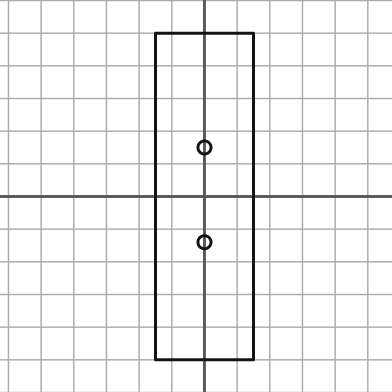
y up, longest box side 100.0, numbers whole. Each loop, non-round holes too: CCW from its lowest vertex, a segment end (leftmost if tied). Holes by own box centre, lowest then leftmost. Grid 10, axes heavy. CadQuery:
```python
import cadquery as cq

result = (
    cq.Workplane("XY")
    .moveTo(-15.0, -50.0)
    .lineTo(15.0, -50.0)
    .lineTo(15.0, 50.0)
    .lineTo(-15.0, 50.0)
    .close()
    .moveTo(0.0, -14.0)
    .circle(2.0)
    .moveTo(0.0, 15.0)
    .circle(2.0)
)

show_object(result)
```